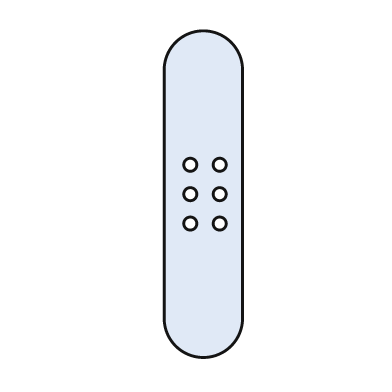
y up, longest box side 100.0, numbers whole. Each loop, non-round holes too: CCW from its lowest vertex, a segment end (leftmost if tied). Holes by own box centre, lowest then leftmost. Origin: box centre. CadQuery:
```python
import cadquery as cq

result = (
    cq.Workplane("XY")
    .moveTo(-12.0, -38.0)
    .threePointArc((0.0, -50.0), (12.0, -38.0))
    .lineTo(12.0, 38.0)
    .threePointArc((0.0, 50.0), (-12.0, 38.0))
    .close()
    .moveTo(-4.0, -9.0)
    .circle(2.0)
    .moveTo(5.0, -9.0)
    .circle(2.0)
    .moveTo(-4.0, 0.0)
    .circle(2.0)
    .moveTo(5.0, 0.0)
    .circle(2.0)
    .moveTo(-4.0, 9.0)
    .circle(2.0)
    .moveTo(5.0, 9.0)
    .circle(2.0)
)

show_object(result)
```